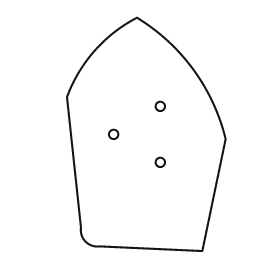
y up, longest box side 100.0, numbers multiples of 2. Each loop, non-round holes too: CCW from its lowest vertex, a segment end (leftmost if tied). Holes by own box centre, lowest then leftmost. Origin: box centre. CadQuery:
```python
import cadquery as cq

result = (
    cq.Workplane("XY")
    .moveTo(24.0, -50.0)
    .lineTo(34.0, -2.0)
    .threePointArc((20.0, 28.0), (-4.0, 50.0))
    .threePointArc((-22.0, 36.0), (-34.0, 16.0))
    .lineTo(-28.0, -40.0)
    .threePointArc((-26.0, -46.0), (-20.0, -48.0))
    .close()
    .moveTo(6.0, -12.0)
    .circle(2.0)
    .moveTo(-14.0, 0.0)
    .circle(2.0)
    .moveTo(6.0, 12.0)
    .circle(2.0)
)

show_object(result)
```